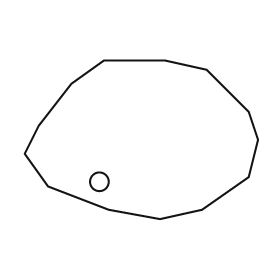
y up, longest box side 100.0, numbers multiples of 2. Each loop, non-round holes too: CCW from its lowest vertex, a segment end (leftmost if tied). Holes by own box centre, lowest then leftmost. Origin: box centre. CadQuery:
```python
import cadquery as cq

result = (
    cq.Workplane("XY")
    .moveTo(8.0, -34.0)
    .lineTo(26.0, -30.0)
    .lineTo(46.0, -16.0)
    .lineTo(50.0, 0.0)
    .lineTo(46.0, 12.0)
    .lineTo(28.0, 30.0)
    .lineTo(10.0, 34.0)
    .lineTo(-16.0, 34.0)
    .lineTo(-30.0, 24.0)
    .lineTo(-44.0, 6.0)
    .lineTo(-50.0, -6.0)
    .lineTo(-40.0, -20.0)
    .lineTo(-14.0, -30.0)
    .close()
    .moveTo(-18.0, -18.0)
    .circle(4.0)
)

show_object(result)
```